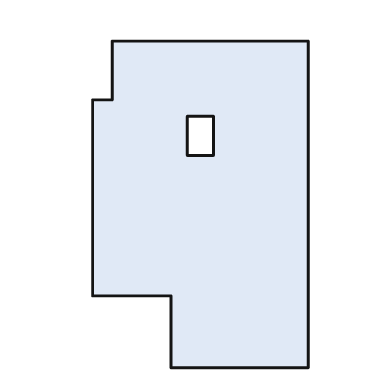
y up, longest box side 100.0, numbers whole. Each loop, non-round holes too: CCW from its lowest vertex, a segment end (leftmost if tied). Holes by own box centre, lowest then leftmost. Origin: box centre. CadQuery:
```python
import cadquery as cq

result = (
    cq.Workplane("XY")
    .moveTo(-9.0, -50.0)
    .lineTo(33.0, -50.0)
    .lineTo(33.0, 50.0)
    .lineTo(-27.0, 50.0)
    .lineTo(-27.0, 32.0)
    .lineTo(-33.0, 32.0)
    .lineTo(-33.0, -28.0)
    .lineTo(-9.0, -28.0)
    .close()
    .moveTo(-4.0, 15.0)
    .lineTo(4.0, 15.0)
    .lineTo(4.0, 27.0)
    .lineTo(-4.0, 27.0)
    .close()
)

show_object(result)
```